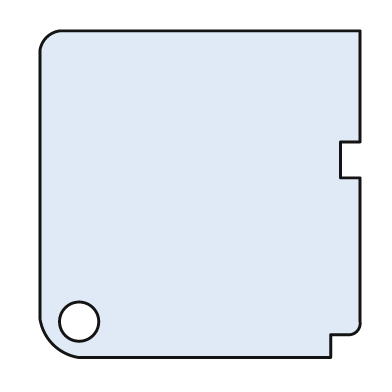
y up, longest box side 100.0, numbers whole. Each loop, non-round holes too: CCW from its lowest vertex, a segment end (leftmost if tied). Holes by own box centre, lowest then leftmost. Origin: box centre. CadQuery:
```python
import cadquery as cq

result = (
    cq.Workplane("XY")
    .moveTo(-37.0, -50.0)
    .lineTo(40.0, -50.0)
    .lineTo(40.0, -43.0)
    .lineTo(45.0, -43.0)
    .threePointArc((48.0, -42.0), (49.0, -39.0))
    .lineTo(49.0, 5.0)
    .lineTo(43.0, 5.0)
    .lineTo(43.0, 16.0)
    .lineTo(49.0, 16.0)
    .lineTo(49.0, 50.0)
    .lineTo(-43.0, 50.0)
    .threePointArc((-47.0, 48.0), (-49.0, 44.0))
    .lineTo(-49.0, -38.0)
    .threePointArc((-45.0, -46.0), (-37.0, -50.0))
    .close()
    .moveTo(-37.0, -39.0)
    .circle(6.0)
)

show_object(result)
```